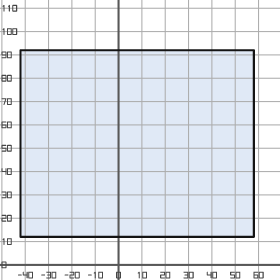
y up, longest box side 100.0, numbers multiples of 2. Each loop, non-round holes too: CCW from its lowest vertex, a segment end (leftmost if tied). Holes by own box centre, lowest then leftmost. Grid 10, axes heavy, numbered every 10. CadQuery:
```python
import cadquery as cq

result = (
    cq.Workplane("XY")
    .moveTo(-42.0, 12.0)
    .lineTo(58.0, 12.0)
    .lineTo(58.0, 92.0)
    .lineTo(-42.0, 92.0)
    .close()
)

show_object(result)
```